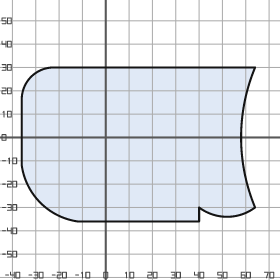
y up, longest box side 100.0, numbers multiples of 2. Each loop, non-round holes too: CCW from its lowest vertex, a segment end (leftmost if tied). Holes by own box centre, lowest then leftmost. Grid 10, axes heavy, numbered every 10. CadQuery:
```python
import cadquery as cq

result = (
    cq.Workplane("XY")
    .moveTo(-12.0, -36.0)
    .lineTo(40.0, -36.0)
    .lineTo(40.0, -30.0)
    .threePointArc((52.0, -34.0), (64.0, -30.0))
    .threePointArc((58.0, 0.0), (64.0, 30.0))
    .lineTo(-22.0, 30.0)
    .threePointArc((-32.0, 26.0), (-36.0, 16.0))
    .lineTo(-36.0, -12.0)
    .threePointArc((-28.0, -28.0), (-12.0, -36.0))
    .close()
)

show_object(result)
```